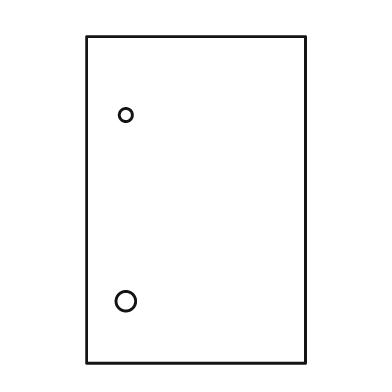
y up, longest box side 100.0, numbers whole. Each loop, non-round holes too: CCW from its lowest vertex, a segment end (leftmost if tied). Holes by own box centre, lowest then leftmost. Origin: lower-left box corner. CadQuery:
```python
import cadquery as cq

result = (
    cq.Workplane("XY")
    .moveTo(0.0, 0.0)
    .lineTo(67.0, 0.0)
    .lineTo(67.0, 100.0)
    .lineTo(0.0, 100.0)
    .close()
    .moveTo(12.0, 19.0)
    .circle(3.0)
    .moveTo(12.0, 76.0)
    .circle(2.0)
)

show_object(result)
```